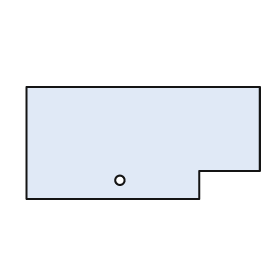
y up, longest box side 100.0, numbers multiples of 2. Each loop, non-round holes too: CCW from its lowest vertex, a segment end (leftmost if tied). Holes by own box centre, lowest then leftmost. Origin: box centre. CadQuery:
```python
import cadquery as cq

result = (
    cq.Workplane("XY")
    .moveTo(-50.0, -24.0)
    .lineTo(24.0, -24.0)
    .lineTo(24.0, -12.0)
    .lineTo(50.0, -12.0)
    .lineTo(50.0, 24.0)
    .lineTo(-50.0, 24.0)
    .close()
    .moveTo(-10.0, -16.0)
    .circle(2.0)
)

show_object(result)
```